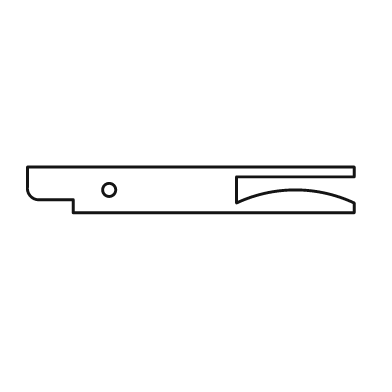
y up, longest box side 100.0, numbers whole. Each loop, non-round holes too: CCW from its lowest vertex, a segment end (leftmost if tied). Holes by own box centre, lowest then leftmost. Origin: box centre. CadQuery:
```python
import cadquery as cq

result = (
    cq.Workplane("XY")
    .moveTo(-36.0, -7.0)
    .lineTo(50.0, -7.0)
    .lineTo(50.0, -4.0)
    .threePointArc((32.0, 0.0), (14.0, -4.0))
    .lineTo(14.0, 4.0)
    .lineTo(50.0, 4.0)
    .lineTo(50.0, 7.0)
    .lineTo(-50.0, 7.0)
    .lineTo(-50.0, 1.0)
    .threePointArc((-49.0, -2.0), (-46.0, -3.0))
    .lineTo(-36.0, -3.0)
    .close()
    .moveTo(-25.0, 0.0)
    .circle(2.0)
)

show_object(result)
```